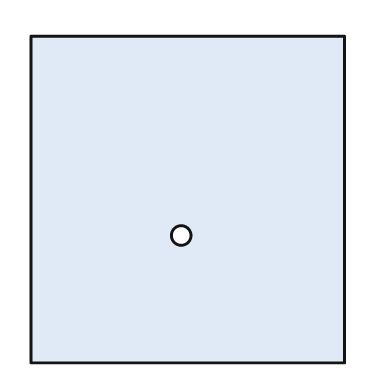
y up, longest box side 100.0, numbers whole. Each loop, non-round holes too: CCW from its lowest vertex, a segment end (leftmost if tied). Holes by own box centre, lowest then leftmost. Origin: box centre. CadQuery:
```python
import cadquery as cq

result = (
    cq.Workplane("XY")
    .moveTo(-48.0, -50.0)
    .lineTo(48.0, -50.0)
    .lineTo(48.0, 50.0)
    .lineTo(-48.0, 50.0)
    .close()
    .moveTo(-2.0, -11.0)
    .circle(3.0)
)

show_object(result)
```